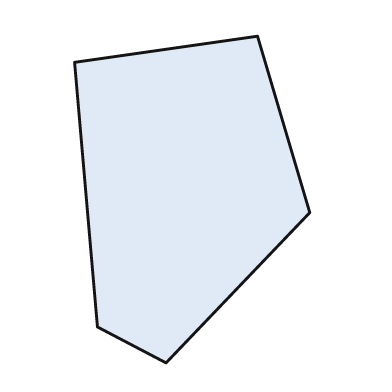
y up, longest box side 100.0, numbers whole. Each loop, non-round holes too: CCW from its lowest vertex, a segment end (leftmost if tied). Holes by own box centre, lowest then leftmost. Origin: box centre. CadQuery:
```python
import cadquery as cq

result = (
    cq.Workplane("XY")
    .moveTo(-8.0, -50.0)
    .lineTo(36.0, -4.0)
    .lineTo(20.0, 50.0)
    .lineTo(-36.0, 42.0)
    .lineTo(-29.0, -39.0)
    .close()
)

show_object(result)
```